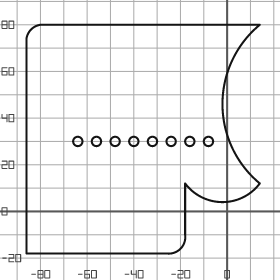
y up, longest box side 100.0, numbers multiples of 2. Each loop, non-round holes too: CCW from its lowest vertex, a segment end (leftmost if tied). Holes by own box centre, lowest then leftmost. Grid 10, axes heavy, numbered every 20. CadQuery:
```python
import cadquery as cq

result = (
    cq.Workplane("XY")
    .moveTo(-86.0, -18.0)
    .lineTo(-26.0, -18.0)
    .threePointArc((-20.0, -16.0), (-18.0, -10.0))
    .lineTo(-18.0, 12.0)
    .threePointArc((-2.0, 4.0), (14.0, 12.0))
    .threePointArc((-2.0, 46.0), (14.0, 80.0))
    .lineTo(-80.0, 80.0)
    .threePointArc((-84.0, 78.0), (-86.0, 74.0))
    .close()
    .moveTo(-64.0, 30.0)
    .circle(2.0)
    .moveTo(-56.0, 30.0)
    .circle(2.0)
    .moveTo(-48.0, 30.0)
    .circle(2.0)
    .moveTo(-40.0, 30.0)
    .circle(2.0)
    .moveTo(-32.0, 30.0)
    .circle(2.0)
    .moveTo(-24.0, 30.0)
    .circle(2.0)
    .moveTo(-16.0, 30.0)
    .circle(2.0)
    .moveTo(-8.0, 30.0)
    .circle(2.0)
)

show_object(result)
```